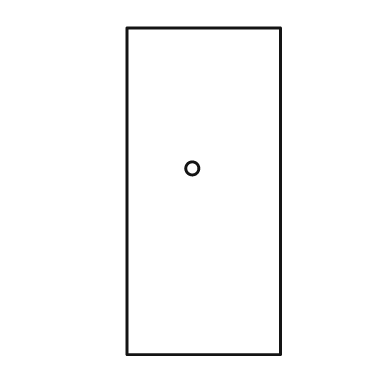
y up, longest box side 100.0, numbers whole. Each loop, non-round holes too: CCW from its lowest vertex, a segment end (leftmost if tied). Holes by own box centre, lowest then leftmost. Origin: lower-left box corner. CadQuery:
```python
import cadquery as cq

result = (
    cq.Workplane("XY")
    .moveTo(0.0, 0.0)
    .lineTo(47.0, 0.0)
    .lineTo(47.0, 100.0)
    .lineTo(0.0, 100.0)
    .close()
    .moveTo(20.0, 57.0)
    .circle(2.0)
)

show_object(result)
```